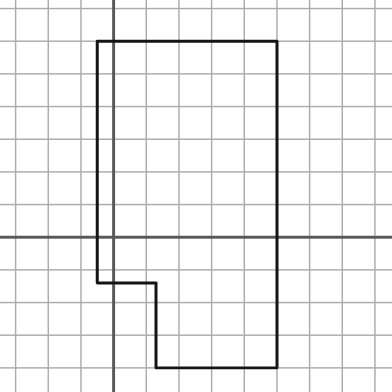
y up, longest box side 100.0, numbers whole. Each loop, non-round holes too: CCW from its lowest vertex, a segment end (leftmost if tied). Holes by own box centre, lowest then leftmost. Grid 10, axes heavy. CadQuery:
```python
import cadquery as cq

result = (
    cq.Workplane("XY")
    .moveTo(13.0, -40.0)
    .lineTo(50.0, -40.0)
    .lineTo(50.0, 60.0)
    .lineTo(-5.0, 60.0)
    .lineTo(-5.0, -14.0)
    .lineTo(13.0, -14.0)
    .close()
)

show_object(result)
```